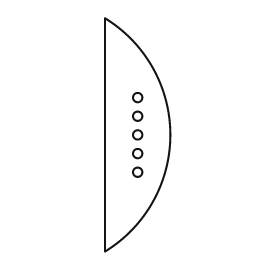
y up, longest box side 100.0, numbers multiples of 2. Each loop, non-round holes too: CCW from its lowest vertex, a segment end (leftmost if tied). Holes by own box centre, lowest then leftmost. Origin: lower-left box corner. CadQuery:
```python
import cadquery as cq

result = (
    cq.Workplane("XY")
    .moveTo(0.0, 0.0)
    .threePointArc((28.0, 50.0), (0.0, 100.0))
    .close()
    .moveTo(14.0, 34.0)
    .circle(2.0)
    .moveTo(14.0, 42.0)
    .circle(2.0)
    .moveTo(14.0, 50.0)
    .circle(2.0)
    .moveTo(14.0, 58.0)
    .circle(2.0)
    .moveTo(14.0, 66.0)
    .circle(2.0)
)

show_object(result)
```